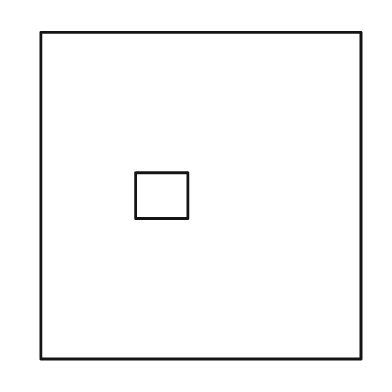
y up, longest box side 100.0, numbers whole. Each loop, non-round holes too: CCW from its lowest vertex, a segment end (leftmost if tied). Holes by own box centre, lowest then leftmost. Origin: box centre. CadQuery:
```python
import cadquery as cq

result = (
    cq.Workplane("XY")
    .moveTo(-49.0, -50.0)
    .lineTo(49.0, -50.0)
    .lineTo(49.0, 50.0)
    .lineTo(-49.0, 50.0)
    .close()
    .moveTo(-20.0, -7.0)
    .lineTo(-4.0, -7.0)
    .lineTo(-4.0, 7.0)
    .lineTo(-20.0, 7.0)
    .close()
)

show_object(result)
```